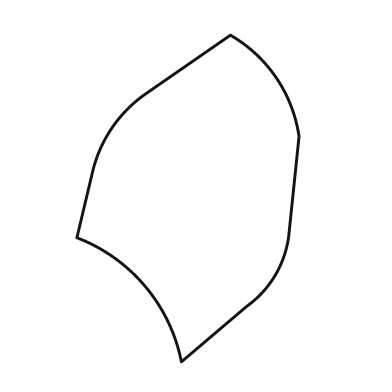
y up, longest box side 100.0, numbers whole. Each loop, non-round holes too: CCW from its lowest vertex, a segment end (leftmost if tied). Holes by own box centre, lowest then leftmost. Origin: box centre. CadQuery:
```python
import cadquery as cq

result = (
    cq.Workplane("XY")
    .moveTo(-2.0, -50.0)
    .lineTo(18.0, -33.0)
    .threePointArc((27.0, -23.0), (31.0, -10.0))
    .lineTo(34.0, 19.0)
    .threePointArc((27.0, 37.0), (13.0, 50.0))
    .lineTo(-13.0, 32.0)
    .threePointArc((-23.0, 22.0), (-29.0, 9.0))
    .lineTo(-34.0, -12.0)
    .threePointArc((-13.0, -27.0), (-2.0, -50.0))
    .close()
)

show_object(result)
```